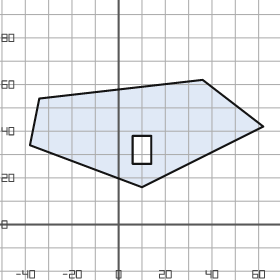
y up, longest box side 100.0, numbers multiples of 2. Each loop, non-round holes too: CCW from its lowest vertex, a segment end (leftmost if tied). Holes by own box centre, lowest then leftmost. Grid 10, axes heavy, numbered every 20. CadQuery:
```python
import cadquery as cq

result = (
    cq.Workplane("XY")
    .moveTo(10.0, 16.0)
    .lineTo(62.0, 42.0)
    .lineTo(36.0, 62.0)
    .lineTo(-34.0, 54.0)
    .lineTo(-38.0, 34.0)
    .close()
    .moveTo(6.0, 26.0)
    .lineTo(14.0, 26.0)
    .lineTo(14.0, 38.0)
    .lineTo(6.0, 38.0)
    .close()
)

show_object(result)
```